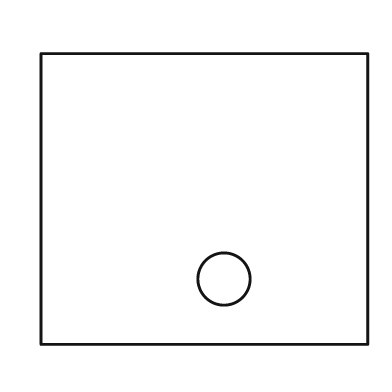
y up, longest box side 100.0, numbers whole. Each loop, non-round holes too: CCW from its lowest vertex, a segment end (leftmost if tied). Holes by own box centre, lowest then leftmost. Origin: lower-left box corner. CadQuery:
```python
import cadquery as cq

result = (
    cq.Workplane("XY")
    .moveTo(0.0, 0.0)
    .lineTo(100.0, 0.0)
    .lineTo(100.0, 89.0)
    .lineTo(0.0, 89.0)
    .close()
    .moveTo(56.0, 20.0)
    .circle(8.0)
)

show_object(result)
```